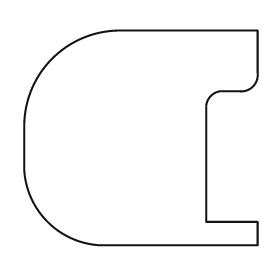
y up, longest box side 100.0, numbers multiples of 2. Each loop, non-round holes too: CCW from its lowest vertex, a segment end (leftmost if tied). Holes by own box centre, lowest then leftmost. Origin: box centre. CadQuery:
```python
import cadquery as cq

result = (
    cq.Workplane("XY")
    .moveTo(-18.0, -46.0)
    .lineTo(50.0, -46.0)
    .lineTo(50.0, -36.0)
    .lineTo(28.0, -36.0)
    .lineTo(28.0, 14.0)
    .threePointArc((30.0, 18.0), (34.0, 20.0))
    .lineTo(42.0, 20.0)
    .threePointArc((48.0, 22.0), (50.0, 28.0))
    .lineTo(50.0, 46.0)
    .lineTo(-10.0, 46.0)
    .threePointArc((-38.0, 34.0), (-50.0, 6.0))
    .lineTo(-50.0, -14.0)
    .threePointArc((-40.0, -36.0), (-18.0, -46.0))
    .close()
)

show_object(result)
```